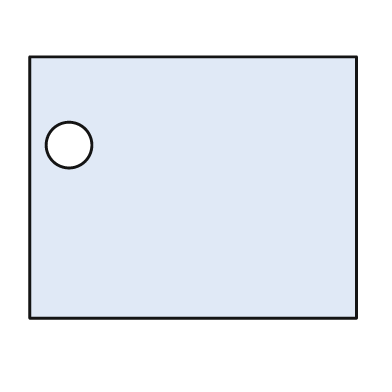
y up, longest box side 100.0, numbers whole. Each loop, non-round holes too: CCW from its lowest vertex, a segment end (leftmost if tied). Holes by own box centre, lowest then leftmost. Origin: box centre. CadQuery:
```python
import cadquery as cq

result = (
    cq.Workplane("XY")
    .moveTo(-50.0, -40.0)
    .lineTo(50.0, -40.0)
    .lineTo(50.0, 40.0)
    .lineTo(-50.0, 40.0)
    .close()
    .moveTo(-38.0, 13.0)
    .circle(7.0)
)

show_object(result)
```